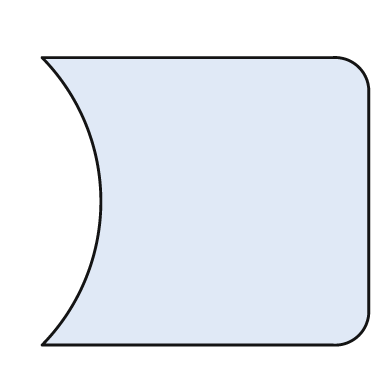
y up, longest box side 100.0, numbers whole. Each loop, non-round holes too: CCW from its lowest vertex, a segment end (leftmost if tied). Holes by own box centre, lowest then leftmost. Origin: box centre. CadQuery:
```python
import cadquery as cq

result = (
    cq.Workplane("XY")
    .moveTo(-50.0, -44.0)
    .lineTo(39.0, -44.0)
    .threePointArc((47.0, -41.0), (50.0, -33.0))
    .lineTo(50.0, 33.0)
    .threePointArc((47.0, 41.0), (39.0, 44.0))
    .lineTo(-50.0, 44.0)
    .threePointArc((-32.0, 0.0), (-50.0, -44.0))
    .close()
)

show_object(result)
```